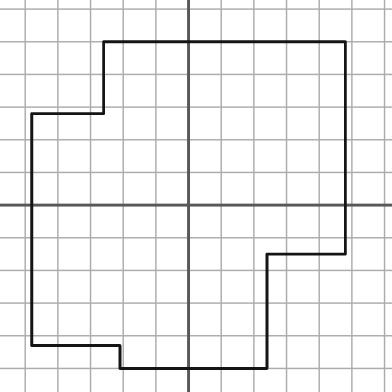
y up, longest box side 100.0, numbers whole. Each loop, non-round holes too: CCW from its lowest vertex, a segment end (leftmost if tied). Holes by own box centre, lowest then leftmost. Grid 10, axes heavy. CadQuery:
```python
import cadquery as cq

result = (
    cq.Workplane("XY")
    .moveTo(-21.0, -50.0)
    .lineTo(24.0, -50.0)
    .lineTo(24.0, -15.0)
    .lineTo(48.0, -15.0)
    .lineTo(48.0, 50.0)
    .lineTo(-26.0, 50.0)
    .lineTo(-26.0, 28.0)
    .lineTo(-48.0, 28.0)
    .lineTo(-48.0, -43.0)
    .lineTo(-21.0, -43.0)
    .close()
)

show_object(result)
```